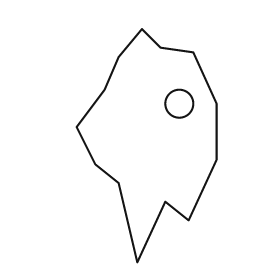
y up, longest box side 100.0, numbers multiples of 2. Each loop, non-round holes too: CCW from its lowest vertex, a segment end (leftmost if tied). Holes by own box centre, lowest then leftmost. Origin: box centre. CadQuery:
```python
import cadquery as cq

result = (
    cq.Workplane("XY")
    .moveTo(-4.0, -50.0)
    .lineTo(8.0, -24.0)
    .lineTo(18.0, -32.0)
    .lineTo(30.0, -6.0)
    .lineTo(30.0, 18.0)
    .lineTo(20.0, 40.0)
    .lineTo(6.0, 42.0)
    .lineTo(-2.0, 50.0)
    .lineTo(-12.0, 38.0)
    .lineTo(-18.0, 24.0)
    .lineTo(-30.0, 8.0)
    .lineTo(-22.0, -8.0)
    .lineTo(-12.0, -16.0)
    .close()
    .moveTo(14.0, 18.0)
    .circle(6.0)
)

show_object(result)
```